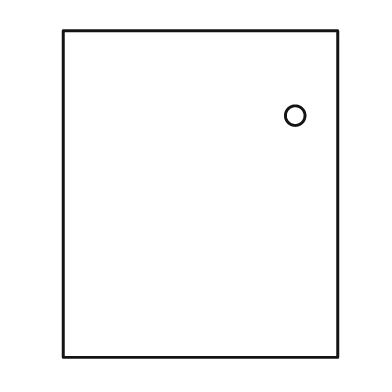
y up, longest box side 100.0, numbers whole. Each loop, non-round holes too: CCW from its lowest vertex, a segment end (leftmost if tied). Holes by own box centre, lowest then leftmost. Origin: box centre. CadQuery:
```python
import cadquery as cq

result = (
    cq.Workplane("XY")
    .moveTo(-42.0, -50.0)
    .lineTo(42.0, -50.0)
    .lineTo(42.0, 50.0)
    .lineTo(-42.0, 50.0)
    .close()
    .moveTo(29.0, 24.0)
    .circle(3.0)
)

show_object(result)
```